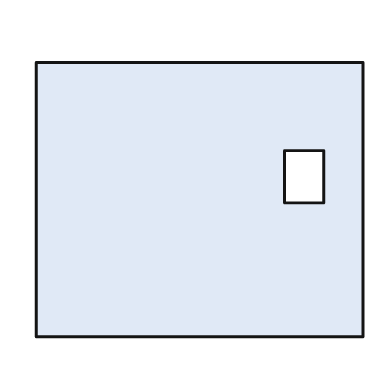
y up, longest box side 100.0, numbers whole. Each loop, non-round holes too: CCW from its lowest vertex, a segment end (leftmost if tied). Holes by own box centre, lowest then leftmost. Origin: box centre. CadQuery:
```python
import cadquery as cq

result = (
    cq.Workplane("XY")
    .moveTo(-50.0, -42.0)
    .lineTo(50.0, -42.0)
    .lineTo(50.0, 42.0)
    .lineTo(-50.0, 42.0)
    .close()
    .moveTo(26.0, -1.0)
    .lineTo(38.0, -1.0)
    .lineTo(38.0, 15.0)
    .lineTo(26.0, 15.0)
    .close()
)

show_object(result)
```